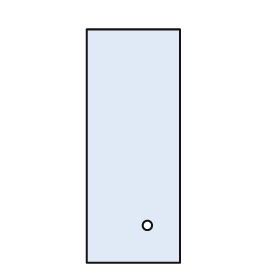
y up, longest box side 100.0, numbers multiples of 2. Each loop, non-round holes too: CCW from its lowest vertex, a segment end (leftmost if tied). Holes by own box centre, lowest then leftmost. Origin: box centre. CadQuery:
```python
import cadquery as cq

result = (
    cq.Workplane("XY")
    .moveTo(-20.0, -50.0)
    .lineTo(20.0, -50.0)
    .lineTo(20.0, 50.0)
    .lineTo(-20.0, 50.0)
    .close()
    .moveTo(6.0, -34.0)
    .circle(2.0)
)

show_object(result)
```